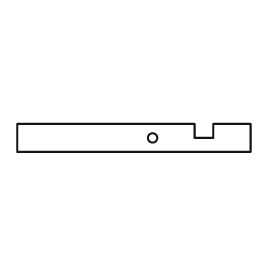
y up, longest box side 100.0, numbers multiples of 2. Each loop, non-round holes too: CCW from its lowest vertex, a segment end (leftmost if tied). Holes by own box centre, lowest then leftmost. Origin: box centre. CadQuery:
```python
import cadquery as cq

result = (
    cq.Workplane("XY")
    .moveTo(-50.0, -6.0)
    .lineTo(50.0, -6.0)
    .lineTo(50.0, 6.0)
    .lineTo(34.0, 6.0)
    .lineTo(34.0, 0.0)
    .lineTo(26.0, 0.0)
    .lineTo(26.0, 6.0)
    .lineTo(-50.0, 6.0)
    .close()
    .moveTo(8.0, 0.0)
    .circle(2.0)
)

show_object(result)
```